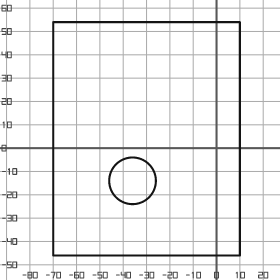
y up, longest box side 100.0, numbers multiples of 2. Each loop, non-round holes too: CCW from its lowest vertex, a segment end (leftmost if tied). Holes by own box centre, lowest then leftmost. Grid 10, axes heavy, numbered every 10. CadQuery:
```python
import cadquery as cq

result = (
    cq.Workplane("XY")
    .moveTo(-70.0, -46.0)
    .lineTo(10.0, -46.0)
    .lineTo(10.0, 54.0)
    .lineTo(-70.0, 54.0)
    .close()
    .moveTo(-36.0, -14.0)
    .circle(10.0)
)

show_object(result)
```